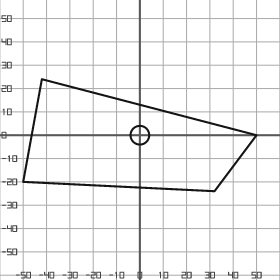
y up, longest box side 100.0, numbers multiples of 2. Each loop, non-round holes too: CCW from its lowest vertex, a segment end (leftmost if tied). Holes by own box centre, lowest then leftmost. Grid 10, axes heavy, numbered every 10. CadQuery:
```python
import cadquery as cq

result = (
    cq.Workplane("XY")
    .moveTo(32.0, -24.0)
    .lineTo(50.0, 0.0)
    .lineTo(-42.0, 24.0)
    .lineTo(-50.0, -20.0)
    .close()
    .moveTo(0.0, 0.0)
    .circle(4.0)
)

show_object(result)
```